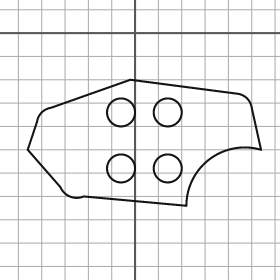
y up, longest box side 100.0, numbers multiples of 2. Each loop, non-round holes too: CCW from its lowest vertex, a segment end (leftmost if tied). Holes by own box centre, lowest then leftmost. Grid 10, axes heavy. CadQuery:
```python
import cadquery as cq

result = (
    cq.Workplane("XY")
    .moveTo(22.0, -74.0)
    .threePointArc((32.0, -54.0), (54.0, -50.0))
    .lineTo(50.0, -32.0)
    .threePointArc((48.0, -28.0), (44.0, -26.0))
    .lineTo(-2.0, -20.0)
    .lineTo(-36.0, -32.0)
    .threePointArc((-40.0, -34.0), (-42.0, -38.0))
    .lineTo(-46.0, -50.0)
    .lineTo(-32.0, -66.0)
    .threePointArc((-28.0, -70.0), (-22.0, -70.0))
    .close()
    .moveTo(-6.0, -58.0)
    .circle(6.0)
    .moveTo(14.0, -58.0)
    .circle(6.0)
    .moveTo(-6.0, -34.0)
    .circle(6.0)
    .moveTo(14.0, -34.0)
    .circle(6.0)
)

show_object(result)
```